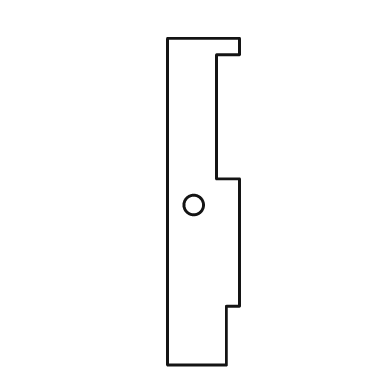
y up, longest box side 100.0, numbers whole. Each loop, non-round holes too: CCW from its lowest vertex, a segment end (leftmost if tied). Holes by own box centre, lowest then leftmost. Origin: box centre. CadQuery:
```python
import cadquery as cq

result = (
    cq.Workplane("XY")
    .moveTo(-11.0, -50.0)
    .lineTo(7.0, -50.0)
    .lineTo(7.0, -32.0)
    .lineTo(11.0, -32.0)
    .lineTo(11.0, 7.0)
    .lineTo(4.0, 7.0)
    .lineTo(4.0, 45.0)
    .lineTo(11.0, 45.0)
    .lineTo(11.0, 50.0)
    .lineTo(-11.0, 50.0)
    .close()
    .moveTo(-3.0, -1.0)
    .circle(3.0)
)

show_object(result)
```